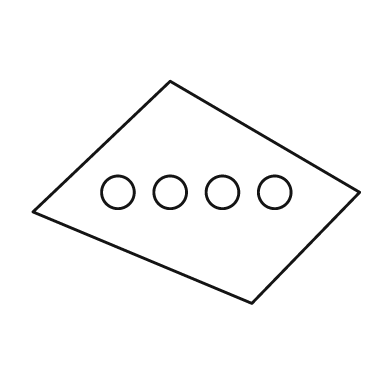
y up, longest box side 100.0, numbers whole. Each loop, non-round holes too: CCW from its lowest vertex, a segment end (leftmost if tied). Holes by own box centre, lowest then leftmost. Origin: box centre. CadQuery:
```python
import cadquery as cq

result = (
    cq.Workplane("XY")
    .moveTo(17.0, -34.0)
    .lineTo(50.0, 0.0)
    .lineTo(-8.0, 34.0)
    .lineTo(-50.0, -6.0)
    .close()
    .moveTo(-24.0, 0.0)
    .circle(5.0)
    .moveTo(-8.0, 0.0)
    .circle(5.0)
    .moveTo(8.0, 0.0)
    .circle(5.0)
    .moveTo(24.0, 0.0)
    .circle(5.0)
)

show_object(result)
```